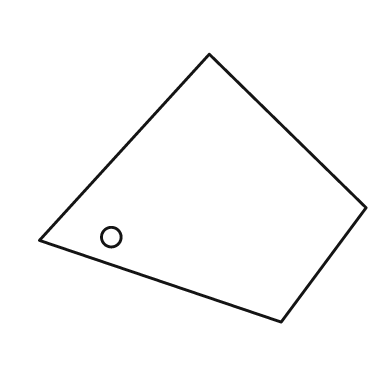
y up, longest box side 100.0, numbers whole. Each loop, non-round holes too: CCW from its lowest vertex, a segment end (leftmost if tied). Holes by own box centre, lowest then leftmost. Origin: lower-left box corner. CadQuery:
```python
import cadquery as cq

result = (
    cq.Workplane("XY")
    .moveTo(74.0, 0.0)
    .lineTo(100.0, 35.0)
    .lineTo(52.0, 82.0)
    .lineTo(0.0, 25.0)
    .close()
    .moveTo(22.0, 26.0)
    .circle(3.0)
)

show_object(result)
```